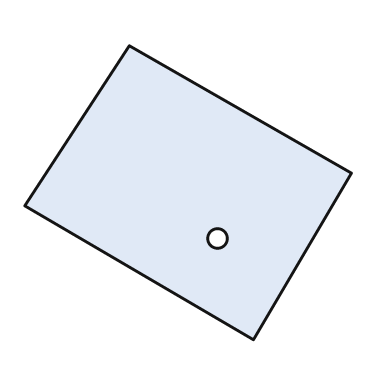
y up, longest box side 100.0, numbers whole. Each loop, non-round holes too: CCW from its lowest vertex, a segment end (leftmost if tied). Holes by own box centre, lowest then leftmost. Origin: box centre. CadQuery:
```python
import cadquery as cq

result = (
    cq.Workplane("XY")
    .moveTo(20.0, -45.0)
    .lineTo(50.0, 6.0)
    .lineTo(-18.0, 45.0)
    .lineTo(-50.0, -4.0)
    .close()
    .moveTo(9.0, -14.0)
    .circle(3.0)
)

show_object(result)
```